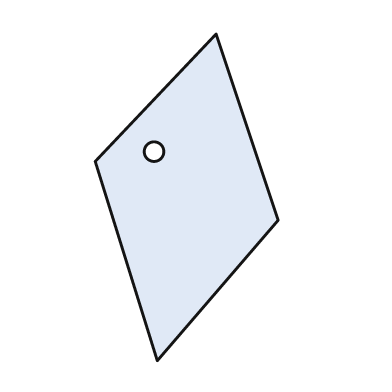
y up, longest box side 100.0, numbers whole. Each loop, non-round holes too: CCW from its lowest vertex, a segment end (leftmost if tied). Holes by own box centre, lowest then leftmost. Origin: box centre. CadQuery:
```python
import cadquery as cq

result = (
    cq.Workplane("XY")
    .moveTo(-9.0, -50.0)
    .lineTo(28.0, -7.0)
    .lineTo(9.0, 50.0)
    .lineTo(-28.0, 11.0)
    .close()
    .moveTo(-10.0, 14.0)
    .circle(3.0)
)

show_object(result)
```